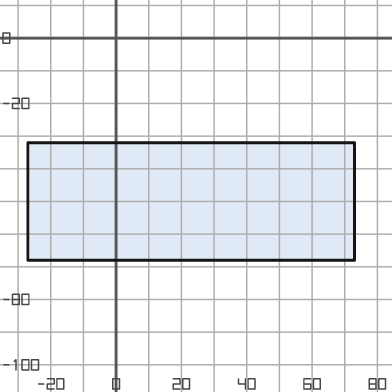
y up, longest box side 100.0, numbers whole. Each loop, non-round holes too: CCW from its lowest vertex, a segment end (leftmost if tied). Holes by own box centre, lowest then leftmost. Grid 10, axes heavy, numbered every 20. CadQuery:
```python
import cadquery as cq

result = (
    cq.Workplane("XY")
    .moveTo(-27.0, -68.0)
    .lineTo(73.0, -68.0)
    .lineTo(73.0, -32.0)
    .lineTo(-27.0, -32.0)
    .close()
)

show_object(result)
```